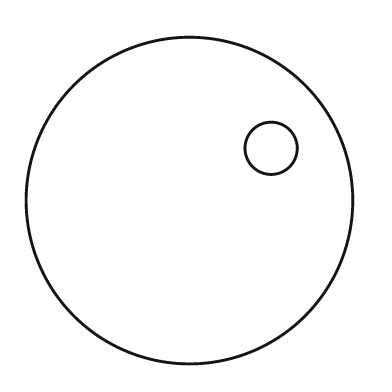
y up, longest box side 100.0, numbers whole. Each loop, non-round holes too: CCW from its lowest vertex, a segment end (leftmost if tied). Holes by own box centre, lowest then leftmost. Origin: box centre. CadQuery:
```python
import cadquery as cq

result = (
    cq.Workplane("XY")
    .moveTo(0.0, 0.0)
    .circle(50.0)
    .moveTo(25.0, 16.0)
    .circle(8.0)
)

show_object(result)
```